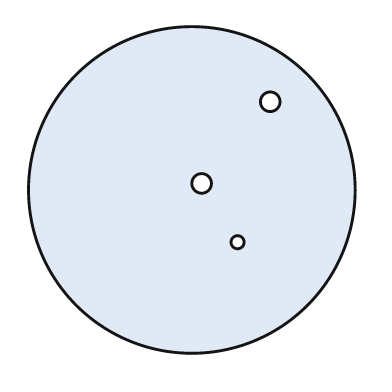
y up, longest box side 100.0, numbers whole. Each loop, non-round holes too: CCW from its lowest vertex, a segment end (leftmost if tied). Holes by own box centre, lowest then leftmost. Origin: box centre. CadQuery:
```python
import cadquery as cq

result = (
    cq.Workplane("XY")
    .moveTo(0.0, 0.0)
    .circle(50.0)
    .moveTo(14.0, -16.0)
    .circle(2.0)
    .moveTo(3.0, 2.0)
    .circle(3.0)
    .moveTo(24.0, 27.0)
    .circle(3.0)
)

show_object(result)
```